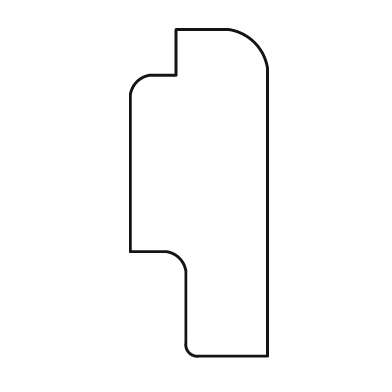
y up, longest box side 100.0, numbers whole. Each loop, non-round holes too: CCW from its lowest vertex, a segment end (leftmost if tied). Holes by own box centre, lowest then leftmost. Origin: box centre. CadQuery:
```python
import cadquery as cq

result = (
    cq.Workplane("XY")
    .moveTo(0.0, -50.0)
    .lineTo(21.0, -50.0)
    .lineTo(21.0, 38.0)
    .threePointArc((17.0, 46.0), (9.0, 50.0))
    .lineTo(-7.0, 50.0)
    .lineTo(-7.0, 36.0)
    .lineTo(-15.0, 36.0)
    .threePointArc((-19.0, 34.0), (-21.0, 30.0))
    .lineTo(-21.0, -18.0)
    .lineTo(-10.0, -18.0)
    .threePointArc((-6.0, -20.0), (-4.0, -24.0))
    .lineTo(-4.0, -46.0)
    .threePointArc((-3.0, -49.0), (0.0, -50.0))
    .close()
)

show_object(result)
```